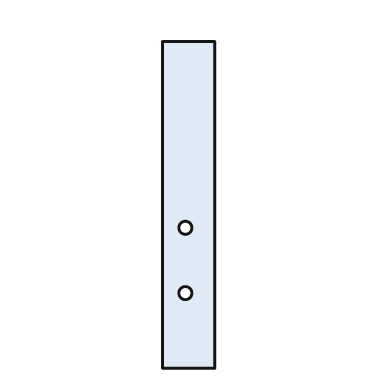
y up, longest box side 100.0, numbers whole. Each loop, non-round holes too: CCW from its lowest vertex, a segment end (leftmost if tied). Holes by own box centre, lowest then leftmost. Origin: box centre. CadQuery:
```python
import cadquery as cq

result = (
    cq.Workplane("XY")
    .moveTo(-8.0, -50.0)
    .lineTo(8.0, -50.0)
    .lineTo(8.0, 50.0)
    .lineTo(-8.0, 50.0)
    .close()
    .moveTo(-1.0, -27.0)
    .circle(2.0)
    .moveTo(-1.0, -7.0)
    .circle(2.0)
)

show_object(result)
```